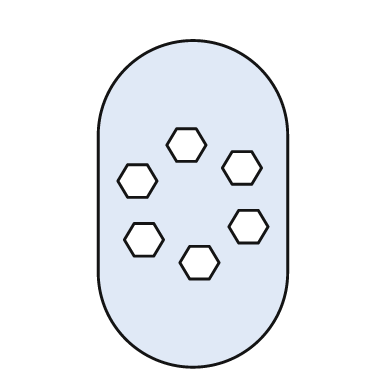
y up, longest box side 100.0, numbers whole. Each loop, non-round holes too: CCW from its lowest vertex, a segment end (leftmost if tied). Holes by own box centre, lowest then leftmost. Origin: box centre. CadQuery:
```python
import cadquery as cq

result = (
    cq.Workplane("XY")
    .moveTo(-29.0, -21.0)
    .threePointArc((0.0, -50.0), (29.0, -21.0))
    .lineTo(29.0, 21.0)
    .threePointArc((0.0, 50.0), (-29.0, 21.0))
    .close()
    .moveTo(-1.0, -23.0)
    .lineTo(5.0, -23.0)
    .lineTo(8.0, -18.0)
    .lineTo(5.0, -13.0)
    .lineTo(-1.0, -13.0)
    .lineTo(-4.0, -18.0)
    .close()
    .moveTo(-18.0, -16.0)
    .lineTo(-12.0, -16.0)
    .lineTo(-9.0, -11.0)
    .lineTo(-12.0, -6.0)
    .lineTo(-18.0, -6.0)
    .lineTo(-21.0, -11.0)
    .close()
    .moveTo(14.0, -12.0)
    .lineTo(20.0, -12.0)
    .lineTo(23.0, -7.0)
    .lineTo(20.0, -2.0)
    .lineTo(14.0, -2.0)
    .lineTo(11.0, -7.0)
    .close()
    .moveTo(-20.0, 2.0)
    .lineTo(-14.0, 2.0)
    .lineTo(-11.0, 7.0)
    .lineTo(-14.0, 12.0)
    .lineTo(-20.0, 12.0)
    .lineTo(-23.0, 7.0)
    .close()
    .moveTo(12.0, 6.0)
    .lineTo(18.0, 6.0)
    .lineTo(21.0, 11.0)
    .lineTo(18.0, 16.0)
    .lineTo(12.0, 16.0)
    .lineTo(9.0, 11.0)
    .close()
    .moveTo(-5.0, 13.0)
    .lineTo(1.0, 13.0)
    .lineTo(4.0, 18.0)
    .lineTo(1.0, 23.0)
    .lineTo(-5.0, 23.0)
    .lineTo(-8.0, 18.0)
    .close()
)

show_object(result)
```